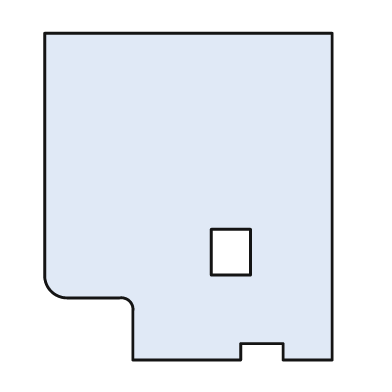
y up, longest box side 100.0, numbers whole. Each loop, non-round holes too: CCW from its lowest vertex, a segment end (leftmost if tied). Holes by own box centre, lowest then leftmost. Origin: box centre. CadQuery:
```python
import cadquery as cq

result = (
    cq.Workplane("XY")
    .moveTo(-17.0, -50.0)
    .lineTo(16.0, -50.0)
    .lineTo(16.0, -45.0)
    .lineTo(29.0, -45.0)
    .lineTo(29.0, -50.0)
    .lineTo(44.0, -50.0)
    .lineTo(44.0, 50.0)
    .lineTo(-44.0, 50.0)
    .lineTo(-44.0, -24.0)
    .threePointArc((-42.0, -29.0), (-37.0, -31.0))
    .lineTo(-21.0, -31.0)
    .threePointArc((-18.0, -32.0), (-17.0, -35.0))
    .close()
    .moveTo(7.0, -24.0)
    .lineTo(19.0, -24.0)
    .lineTo(19.0, -10.0)
    .lineTo(7.0, -10.0)
    .close()
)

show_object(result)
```